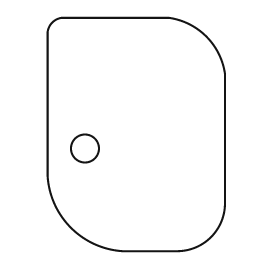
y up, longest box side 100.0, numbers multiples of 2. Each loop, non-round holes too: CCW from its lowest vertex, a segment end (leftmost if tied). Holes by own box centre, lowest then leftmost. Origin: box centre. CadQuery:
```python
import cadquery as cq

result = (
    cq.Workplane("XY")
    .moveTo(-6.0, -50.0)
    .lineTo(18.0, -50.0)
    .threePointArc((32.0, -44.0), (38.0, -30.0))
    .lineTo(38.0, 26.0)
    .threePointArc((30.0, 42.0), (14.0, 50.0))
    .lineTo(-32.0, 50.0)
    .threePointArc((-36.0, 48.0), (-38.0, 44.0))
    .lineTo(-38.0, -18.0)
    .threePointArc((-28.0, -40.0), (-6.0, -50.0))
    .close()
    .moveTo(-22.0, -6.0)
    .circle(6.0)
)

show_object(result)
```